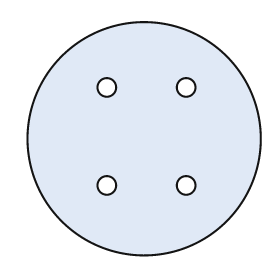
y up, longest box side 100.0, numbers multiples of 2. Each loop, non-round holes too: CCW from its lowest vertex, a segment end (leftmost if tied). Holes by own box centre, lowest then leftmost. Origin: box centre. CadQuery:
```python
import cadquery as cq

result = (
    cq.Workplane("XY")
    .moveTo(0.0, 0.0)
    .circle(50.0)
    .moveTo(-16.0, -20.0)
    .circle(4.0)
    .moveTo(18.0, -20.0)
    .circle(4.0)
    .moveTo(-16.0, 22.0)
    .circle(4.0)
    .moveTo(18.0, 22.0)
    .circle(4.0)
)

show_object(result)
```